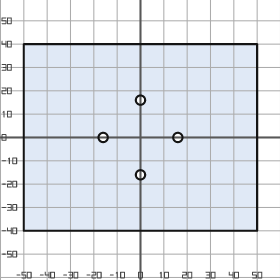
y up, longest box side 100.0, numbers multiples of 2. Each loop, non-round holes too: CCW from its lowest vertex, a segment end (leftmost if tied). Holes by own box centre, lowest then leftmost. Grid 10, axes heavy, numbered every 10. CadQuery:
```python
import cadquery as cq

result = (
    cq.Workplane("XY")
    .moveTo(-50.0, -40.0)
    .lineTo(50.0, -40.0)
    .lineTo(50.0, 40.0)
    .lineTo(-50.0, 40.0)
    .close()
    .moveTo(0.0, -16.0)
    .circle(2.0)
    .moveTo(-16.0, 0.0)
    .circle(2.0)
    .moveTo(16.0, 0.0)
    .circle(2.0)
    .moveTo(0.0, 16.0)
    .circle(2.0)
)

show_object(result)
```